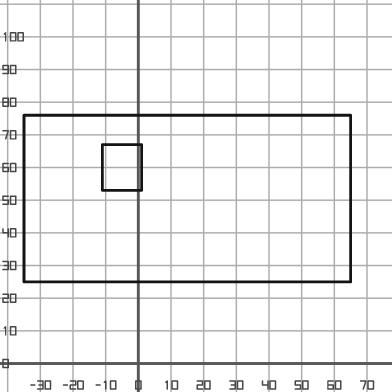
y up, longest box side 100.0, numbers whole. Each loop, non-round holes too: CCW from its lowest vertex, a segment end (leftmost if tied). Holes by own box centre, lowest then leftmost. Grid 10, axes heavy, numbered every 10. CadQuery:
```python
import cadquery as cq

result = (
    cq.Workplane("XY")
    .moveTo(-35.0, 25.0)
    .lineTo(65.0, 25.0)
    .lineTo(65.0, 76.0)
    .lineTo(-35.0, 76.0)
    .close()
    .moveTo(-11.0, 53.0)
    .lineTo(1.0, 53.0)
    .lineTo(1.0, 67.0)
    .lineTo(-11.0, 67.0)
    .close()
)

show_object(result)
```